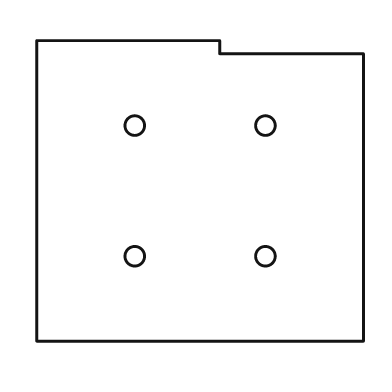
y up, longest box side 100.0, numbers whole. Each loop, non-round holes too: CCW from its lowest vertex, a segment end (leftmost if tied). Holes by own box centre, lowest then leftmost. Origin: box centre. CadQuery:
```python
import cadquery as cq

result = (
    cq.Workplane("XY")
    .moveTo(-50.0, -46.0)
    .lineTo(50.0, -46.0)
    .lineTo(50.0, 42.0)
    .lineTo(6.0, 42.0)
    .lineTo(6.0, 46.0)
    .lineTo(-50.0, 46.0)
    .close()
    .moveTo(-20.0, -20.0)
    .circle(3.0)
    .moveTo(20.0, -20.0)
    .circle(3.0)
    .moveTo(-20.0, 20.0)
    .circle(3.0)
    .moveTo(20.0, 20.0)
    .circle(3.0)
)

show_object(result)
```